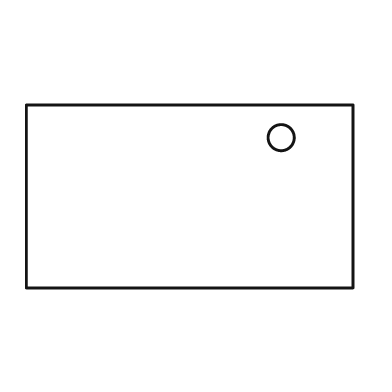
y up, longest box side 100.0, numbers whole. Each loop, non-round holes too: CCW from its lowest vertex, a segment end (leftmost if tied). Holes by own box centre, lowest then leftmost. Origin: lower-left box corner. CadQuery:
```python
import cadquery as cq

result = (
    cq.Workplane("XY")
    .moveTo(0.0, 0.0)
    .lineTo(100.0, 0.0)
    .lineTo(100.0, 56.0)
    .lineTo(0.0, 56.0)
    .close()
    .moveTo(78.0, 46.0)
    .circle(4.0)
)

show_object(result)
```